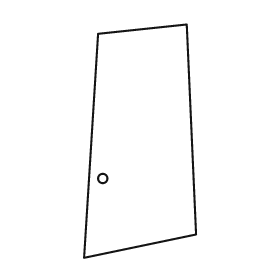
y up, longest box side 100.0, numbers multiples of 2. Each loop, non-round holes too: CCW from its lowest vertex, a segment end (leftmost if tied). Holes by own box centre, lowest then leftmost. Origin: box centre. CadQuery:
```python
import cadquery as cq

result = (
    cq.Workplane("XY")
    .moveTo(-24.0, -50.0)
    .lineTo(24.0, -40.0)
    .lineTo(20.0, 50.0)
    .lineTo(-18.0, 46.0)
    .close()
    .moveTo(-16.0, -16.0)
    .circle(2.0)
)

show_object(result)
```